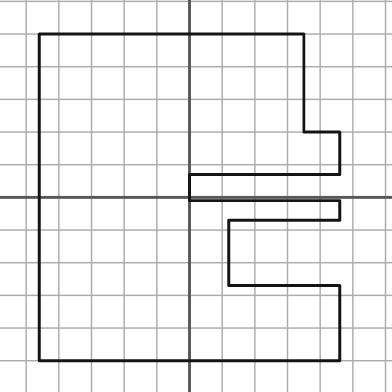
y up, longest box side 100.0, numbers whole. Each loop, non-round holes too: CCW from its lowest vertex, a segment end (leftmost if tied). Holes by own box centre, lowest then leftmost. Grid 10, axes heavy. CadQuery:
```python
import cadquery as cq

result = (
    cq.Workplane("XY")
    .moveTo(-46.0, -50.0)
    .lineTo(46.0, -50.0)
    .lineTo(46.0, -27.0)
    .lineTo(12.0, -27.0)
    .lineTo(12.0, -7.0)
    .lineTo(46.0, -7.0)
    .lineTo(46.0, -1.0)
    .lineTo(0.0, -1.0)
    .lineTo(0.0, 7.0)
    .lineTo(46.0, 7.0)
    .lineTo(46.0, 20.0)
    .lineTo(35.0, 20.0)
    .lineTo(35.0, 50.0)
    .lineTo(-46.0, 50.0)
    .close()
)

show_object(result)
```